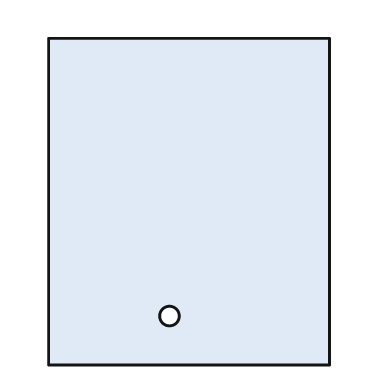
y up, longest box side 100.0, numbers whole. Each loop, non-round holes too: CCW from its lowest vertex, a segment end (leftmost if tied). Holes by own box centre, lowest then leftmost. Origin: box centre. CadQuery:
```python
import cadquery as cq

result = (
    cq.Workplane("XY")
    .moveTo(-43.0, -50.0)
    .lineTo(43.0, -50.0)
    .lineTo(43.0, 50.0)
    .lineTo(-43.0, 50.0)
    .close()
    .moveTo(-6.0, -35.0)
    .circle(3.0)
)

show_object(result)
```